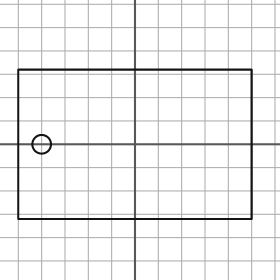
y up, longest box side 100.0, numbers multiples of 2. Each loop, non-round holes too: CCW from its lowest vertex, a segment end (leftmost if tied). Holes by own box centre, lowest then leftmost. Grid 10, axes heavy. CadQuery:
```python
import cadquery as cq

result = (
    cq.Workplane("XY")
    .moveTo(-50.0, -32.0)
    .lineTo(50.0, -32.0)
    .lineTo(50.0, 32.0)
    .lineTo(-50.0, 32.0)
    .close()
    .moveTo(-40.0, 0.0)
    .circle(4.0)
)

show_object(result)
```